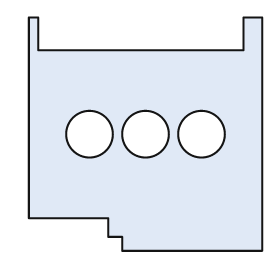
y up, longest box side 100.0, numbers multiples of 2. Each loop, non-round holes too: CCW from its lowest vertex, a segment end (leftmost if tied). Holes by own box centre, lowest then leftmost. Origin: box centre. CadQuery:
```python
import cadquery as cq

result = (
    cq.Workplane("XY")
    .moveTo(-10.0, -50.0)
    .lineTo(50.0, -50.0)
    .lineTo(50.0, 50.0)
    .lineTo(42.0, 50.0)
    .lineTo(42.0, 36.0)
    .lineTo(-46.0, 36.0)
    .lineTo(-46.0, 50.0)
    .lineTo(-50.0, 50.0)
    .lineTo(-50.0, -36.0)
    .lineTo(-16.0, -36.0)
    .lineTo(-16.0, -44.0)
    .lineTo(-10.0, -44.0)
    .close()
    .moveTo(-24.0, 0.0)
    .circle(10.0)
    .moveTo(0.0, 0.0)
    .circle(10.0)
    .moveTo(24.0, 0.0)
    .circle(10.0)
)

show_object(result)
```